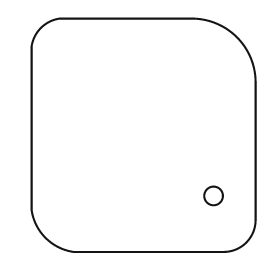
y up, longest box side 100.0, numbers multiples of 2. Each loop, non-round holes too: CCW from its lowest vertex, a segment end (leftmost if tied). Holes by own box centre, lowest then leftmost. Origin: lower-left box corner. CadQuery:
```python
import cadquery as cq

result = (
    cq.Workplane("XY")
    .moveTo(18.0, 0.0)
    .lineTo(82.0, 0.0)
    .threePointArc((92.0, 4.0), (96.0, 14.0))
    .lineTo(96.0, 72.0)
    .threePointArc((88.0, 92.0), (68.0, 100.0))
    .lineTo(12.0, 100.0)
    .threePointArc((4.0, 96.0), (0.0, 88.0))
    .lineTo(0.0, 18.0)
    .threePointArc((6.0, 6.0), (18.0, 0.0))
    .close()
    .moveTo(78.0, 24.0)
    .circle(4.0)
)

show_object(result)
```